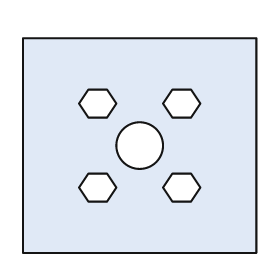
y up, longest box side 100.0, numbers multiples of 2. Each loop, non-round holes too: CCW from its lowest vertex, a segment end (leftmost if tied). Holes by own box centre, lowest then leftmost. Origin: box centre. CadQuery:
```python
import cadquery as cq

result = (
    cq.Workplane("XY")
    .moveTo(-50.0, -46.0)
    .lineTo(50.0, -46.0)
    .lineTo(50.0, 46.0)
    .lineTo(-50.0, 46.0)
    .close()
    .moveTo(-22.0, -24.0)
    .lineTo(-14.0, -24.0)
    .lineTo(-10.0, -18.0)
    .lineTo(-14.0, -12.0)
    .lineTo(-22.0, -12.0)
    .lineTo(-26.0, -18.0)
    .close()
    .moveTo(14.0, -24.0)
    .lineTo(22.0, -24.0)
    .lineTo(26.0, -18.0)
    .lineTo(22.0, -12.0)
    .lineTo(14.0, -12.0)
    .lineTo(10.0, -18.0)
    .close()
    .moveTo(0.0, 0.0)
    .circle(10.0)
    .moveTo(-22.0, 12.0)
    .lineTo(-14.0, 12.0)
    .lineTo(-10.0, 18.0)
    .lineTo(-14.0, 24.0)
    .lineTo(-22.0, 24.0)
    .lineTo(-26.0, 18.0)
    .close()
    .moveTo(14.0, 12.0)
    .lineTo(22.0, 12.0)
    .lineTo(26.0, 18.0)
    .lineTo(22.0, 24.0)
    .lineTo(14.0, 24.0)
    .lineTo(10.0, 18.0)
    .close()
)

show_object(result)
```